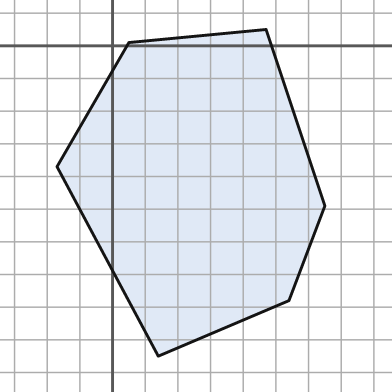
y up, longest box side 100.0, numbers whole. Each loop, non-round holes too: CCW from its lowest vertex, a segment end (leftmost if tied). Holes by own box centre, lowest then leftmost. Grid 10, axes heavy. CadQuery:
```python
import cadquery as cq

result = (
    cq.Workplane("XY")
    .moveTo(14.0, -95.0)
    .lineTo(54.0, -78.0)
    .lineTo(65.0, -49.0)
    .lineTo(47.0, 5.0)
    .lineTo(5.0, 1.0)
    .lineTo(-17.0, -37.0)
    .close()
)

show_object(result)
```